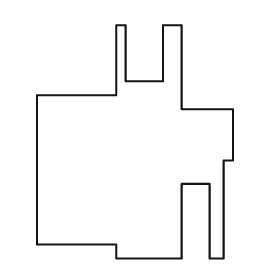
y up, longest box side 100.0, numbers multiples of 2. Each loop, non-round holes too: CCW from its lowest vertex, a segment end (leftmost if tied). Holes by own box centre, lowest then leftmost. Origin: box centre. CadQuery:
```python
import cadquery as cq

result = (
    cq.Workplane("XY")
    .moveTo(-8.0, -50.0)
    .lineTo(20.0, -50.0)
    .lineTo(20.0, -18.0)
    .lineTo(32.0, -18.0)
    .lineTo(32.0, -50.0)
    .lineTo(38.0, -50.0)
    .lineTo(38.0, -8.0)
    .lineTo(42.0, -8.0)
    .lineTo(42.0, 14.0)
    .lineTo(20.0, 14.0)
    .lineTo(20.0, 50.0)
    .lineTo(12.0, 50.0)
    .lineTo(12.0, 26.0)
    .lineTo(-4.0, 26.0)
    .lineTo(-4.0, 50.0)
    .lineTo(-8.0, 50.0)
    .lineTo(-8.0, 20.0)
    .lineTo(-42.0, 20.0)
    .lineTo(-42.0, -44.0)
    .lineTo(-8.0, -44.0)
    .close()
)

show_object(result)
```